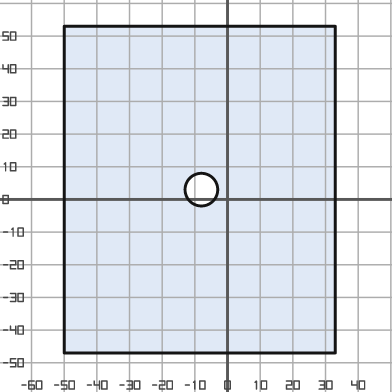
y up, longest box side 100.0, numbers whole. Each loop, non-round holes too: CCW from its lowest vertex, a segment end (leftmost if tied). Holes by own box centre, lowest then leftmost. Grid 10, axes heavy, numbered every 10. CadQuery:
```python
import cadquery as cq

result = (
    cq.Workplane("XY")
    .moveTo(-50.0, -47.0)
    .lineTo(33.0, -47.0)
    .lineTo(33.0, 53.0)
    .lineTo(-50.0, 53.0)
    .close()
    .moveTo(-8.0, 3.0)
    .circle(5.0)
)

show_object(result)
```